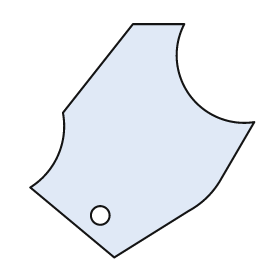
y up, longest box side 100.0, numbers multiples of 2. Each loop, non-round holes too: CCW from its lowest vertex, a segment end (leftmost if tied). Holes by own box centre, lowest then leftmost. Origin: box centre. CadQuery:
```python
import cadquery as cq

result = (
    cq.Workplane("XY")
    .moveTo(-12.0, -50.0)
    .lineTo(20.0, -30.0)
    .threePointArc((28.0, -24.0), (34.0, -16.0))
    .lineTo(48.0, 8.0)
    .threePointArc((20.0, 20.0), (18.0, 50.0))
    .lineTo(-4.0, 50.0)
    .lineTo(-34.0, 12.0)
    .threePointArc((-36.0, -6.0), (-48.0, -20.0))
    .close()
    .moveTo(-18.0, -32.0)
    .circle(4.0)
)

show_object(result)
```